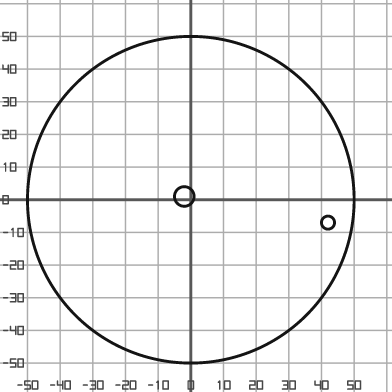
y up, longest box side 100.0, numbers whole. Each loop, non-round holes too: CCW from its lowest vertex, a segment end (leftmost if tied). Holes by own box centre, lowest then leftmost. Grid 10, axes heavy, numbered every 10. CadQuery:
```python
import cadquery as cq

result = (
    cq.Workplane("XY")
    .moveTo(0.0, 0.0)
    .circle(50.0)
    .moveTo(42.0, -7.0)
    .circle(2.0)
    .moveTo(-2.0, 1.0)
    .circle(3.0)
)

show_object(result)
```